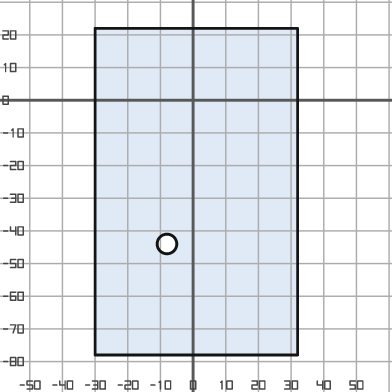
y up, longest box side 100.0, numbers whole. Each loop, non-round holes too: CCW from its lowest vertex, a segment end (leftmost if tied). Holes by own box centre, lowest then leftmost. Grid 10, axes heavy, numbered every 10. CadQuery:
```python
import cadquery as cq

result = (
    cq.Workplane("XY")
    .moveTo(-30.0, -78.0)
    .lineTo(32.0, -78.0)
    .lineTo(32.0, 22.0)
    .lineTo(-30.0, 22.0)
    .close()
    .moveTo(-8.0, -44.0)
    .circle(3.0)
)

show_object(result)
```